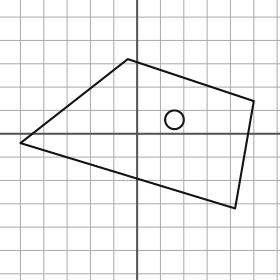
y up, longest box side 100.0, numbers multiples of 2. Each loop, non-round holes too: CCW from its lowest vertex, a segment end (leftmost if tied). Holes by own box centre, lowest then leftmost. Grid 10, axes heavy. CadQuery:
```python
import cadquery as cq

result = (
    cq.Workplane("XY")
    .moveTo(42.0, -32.0)
    .lineTo(50.0, 14.0)
    .lineTo(-4.0, 32.0)
    .lineTo(-50.0, -4.0)
    .close()
    .moveTo(16.0, 6.0)
    .circle(4.0)
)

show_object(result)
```